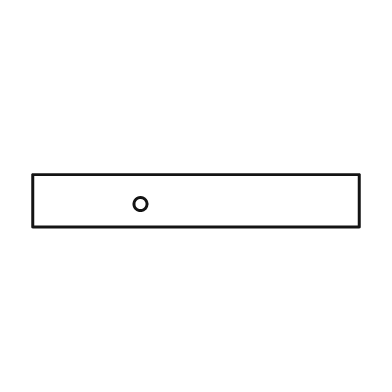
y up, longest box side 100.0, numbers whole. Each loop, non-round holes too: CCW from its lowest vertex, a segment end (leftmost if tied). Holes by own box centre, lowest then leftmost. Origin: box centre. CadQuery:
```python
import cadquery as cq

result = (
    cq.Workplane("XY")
    .moveTo(-50.0, -8.0)
    .lineTo(50.0, -8.0)
    .lineTo(50.0, 8.0)
    .lineTo(-50.0, 8.0)
    .close()
    .moveTo(-17.0, -1.0)
    .circle(2.0)
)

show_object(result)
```